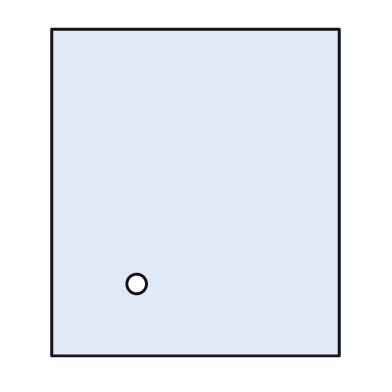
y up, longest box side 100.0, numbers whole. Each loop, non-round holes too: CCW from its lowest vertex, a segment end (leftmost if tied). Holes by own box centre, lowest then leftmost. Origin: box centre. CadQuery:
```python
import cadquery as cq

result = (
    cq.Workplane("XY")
    .moveTo(-44.0, -50.0)
    .lineTo(44.0, -50.0)
    .lineTo(44.0, 50.0)
    .lineTo(-44.0, 50.0)
    .close()
    .moveTo(-18.0, -28.0)
    .circle(3.0)
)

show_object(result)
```